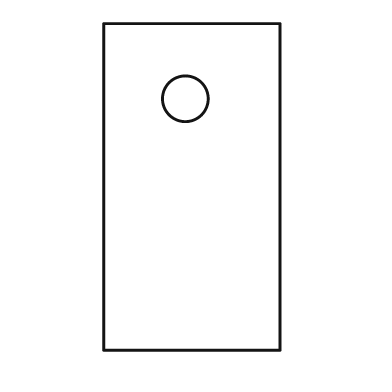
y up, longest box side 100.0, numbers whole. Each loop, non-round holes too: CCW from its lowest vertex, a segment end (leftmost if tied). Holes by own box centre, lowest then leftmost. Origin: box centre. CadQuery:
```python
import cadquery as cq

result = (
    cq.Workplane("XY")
    .moveTo(-27.0, -50.0)
    .lineTo(27.0, -50.0)
    .lineTo(27.0, 50.0)
    .lineTo(-27.0, 50.0)
    .close()
    .moveTo(-2.0, 27.0)
    .circle(7.0)
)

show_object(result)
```